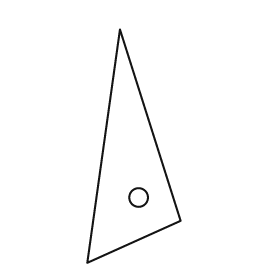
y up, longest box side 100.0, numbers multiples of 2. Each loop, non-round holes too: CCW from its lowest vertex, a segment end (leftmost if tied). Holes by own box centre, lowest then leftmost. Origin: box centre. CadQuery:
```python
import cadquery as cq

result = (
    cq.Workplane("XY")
    .moveTo(-20.0, -50.0)
    .lineTo(20.0, -32.0)
    .lineTo(-6.0, 50.0)
    .close()
    .moveTo(2.0, -22.0)
    .circle(4.0)
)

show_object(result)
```